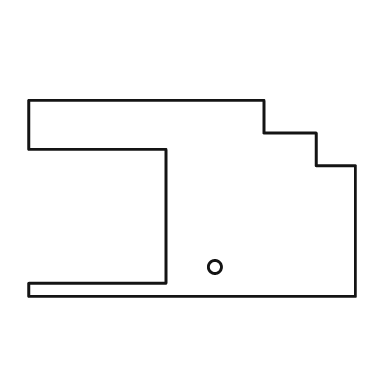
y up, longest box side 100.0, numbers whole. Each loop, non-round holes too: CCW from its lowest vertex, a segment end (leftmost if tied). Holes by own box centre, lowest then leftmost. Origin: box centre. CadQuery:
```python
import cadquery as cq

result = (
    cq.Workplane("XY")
    .moveTo(-50.0, -30.0)
    .lineTo(50.0, -30.0)
    .lineTo(50.0, 10.0)
    .lineTo(38.0, 10.0)
    .lineTo(38.0, 20.0)
    .lineTo(22.0, 20.0)
    .lineTo(22.0, 30.0)
    .lineTo(-50.0, 30.0)
    .lineTo(-50.0, 15.0)
    .lineTo(-8.0, 15.0)
    .lineTo(-8.0, -26.0)
    .lineTo(-50.0, -26.0)
    .close()
    .moveTo(7.0, -21.0)
    .circle(2.0)
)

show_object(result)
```